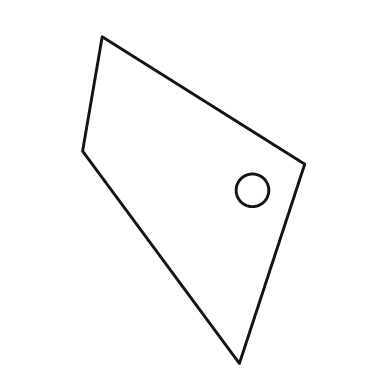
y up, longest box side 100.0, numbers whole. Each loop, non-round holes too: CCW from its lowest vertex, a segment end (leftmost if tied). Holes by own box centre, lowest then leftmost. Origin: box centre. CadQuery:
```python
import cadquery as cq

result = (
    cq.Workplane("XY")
    .moveTo(14.0, -50.0)
    .lineTo(34.0, 11.0)
    .lineTo(-28.0, 50.0)
    .lineTo(-34.0, 15.0)
    .close()
    .moveTo(18.0, 3.0)
    .circle(5.0)
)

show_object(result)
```